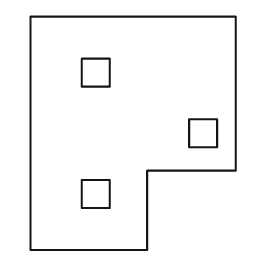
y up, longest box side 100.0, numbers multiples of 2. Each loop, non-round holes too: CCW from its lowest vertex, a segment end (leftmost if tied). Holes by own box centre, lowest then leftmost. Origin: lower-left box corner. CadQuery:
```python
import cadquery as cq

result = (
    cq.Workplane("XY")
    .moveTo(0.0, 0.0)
    .lineTo(50.0, 0.0)
    .lineTo(50.0, 34.0)
    .lineTo(88.0, 34.0)
    .lineTo(88.0, 100.0)
    .lineTo(0.0, 100.0)
    .close()
    .moveTo(22.0, 18.0)
    .lineTo(34.0, 18.0)
    .lineTo(34.0, 30.0)
    .lineTo(22.0, 30.0)
    .close()
    .moveTo(68.0, 44.0)
    .lineTo(80.0, 44.0)
    .lineTo(80.0, 56.0)
    .lineTo(68.0, 56.0)
    .close()
    .moveTo(22.0, 70.0)
    .lineTo(34.0, 70.0)
    .lineTo(34.0, 82.0)
    .lineTo(22.0, 82.0)
    .close()
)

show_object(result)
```